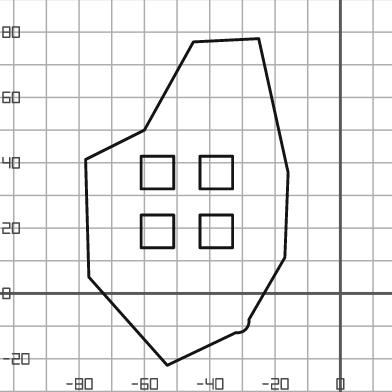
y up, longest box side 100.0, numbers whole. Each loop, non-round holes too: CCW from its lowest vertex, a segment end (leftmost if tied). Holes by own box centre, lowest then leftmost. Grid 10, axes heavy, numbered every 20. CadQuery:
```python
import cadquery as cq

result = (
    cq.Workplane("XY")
    .moveTo(-53.0, -22.0)
    .lineTo(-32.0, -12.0)
    .threePointArc((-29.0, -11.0), (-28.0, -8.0))
    .lineTo(-17.0, 11.0)
    .lineTo(-16.0, 37.0)
    .lineTo(-25.0, 78.0)
    .lineTo(-45.0, 77.0)
    .lineTo(-60.0, 50.0)
    .lineTo(-78.0, 41.0)
    .lineTo(-77.0, 5.0)
    .close()
    .moveTo(-61.0, 14.0)
    .lineTo(-51.0, 14.0)
    .lineTo(-51.0, 24.0)
    .lineTo(-61.0, 24.0)
    .close()
    .moveTo(-43.0, 14.0)
    .lineTo(-33.0, 14.0)
    .lineTo(-33.0, 24.0)
    .lineTo(-43.0, 24.0)
    .close()
    .moveTo(-61.0, 32.0)
    .lineTo(-51.0, 32.0)
    .lineTo(-51.0, 42.0)
    .lineTo(-61.0, 42.0)
    .close()
    .moveTo(-43.0, 32.0)
    .lineTo(-33.0, 32.0)
    .lineTo(-33.0, 42.0)
    .lineTo(-43.0, 42.0)
    .close()
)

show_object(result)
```